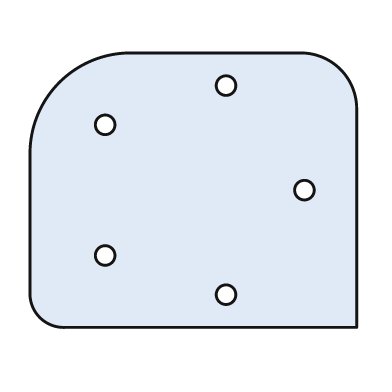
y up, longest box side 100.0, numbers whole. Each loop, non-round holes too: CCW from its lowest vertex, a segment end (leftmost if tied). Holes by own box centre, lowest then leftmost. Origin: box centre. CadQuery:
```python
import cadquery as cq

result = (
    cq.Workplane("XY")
    .moveTo(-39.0, -42.0)
    .lineTo(50.0, -42.0)
    .lineTo(50.0, 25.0)
    .threePointArc((45.0, 37.0), (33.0, 42.0))
    .lineTo(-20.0, 42.0)
    .threePointArc((-41.0, 33.0), (-50.0, 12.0))
    .lineTo(-50.0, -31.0)
    .threePointArc((-47.0, -39.0), (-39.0, -42.0))
    .close()
    .moveTo(10.0, -32.0)
    .circle(3.0)
    .moveTo(-27.0, -20.0)
    .circle(3.0)
    .moveTo(34.0, 0.0)
    .circle(3.0)
    .moveTo(-27.0, 20.0)
    .circle(3.0)
    .moveTo(10.0, 32.0)
    .circle(3.0)
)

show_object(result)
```